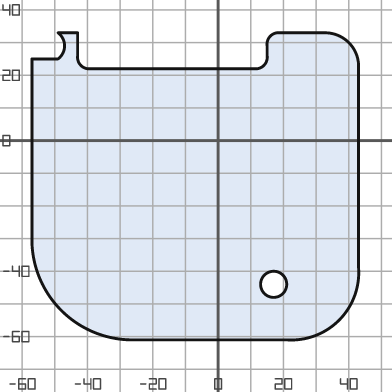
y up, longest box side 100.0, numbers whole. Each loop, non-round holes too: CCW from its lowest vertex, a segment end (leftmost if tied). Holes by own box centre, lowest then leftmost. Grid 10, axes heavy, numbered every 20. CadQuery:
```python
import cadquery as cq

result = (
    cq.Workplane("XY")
    .moveTo(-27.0, -61.0)
    .lineTo(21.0, -61.0)
    .threePointArc((37.0, -55.0), (43.0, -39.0))
    .lineTo(43.0, 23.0)
    .threePointArc((40.0, 30.0), (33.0, 33.0))
    .lineTo(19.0, 33.0)
    .threePointArc((16.0, 32.0), (15.0, 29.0))
    .lineTo(15.0, 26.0)
    .threePointArc((14.0, 23.0), (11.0, 22.0))
    .lineTo(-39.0, 22.0)
    .threePointArc((-42.0, 23.0), (-43.0, 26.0))
    .lineTo(-43.0, 33.0)
    .lineTo(-49.0, 33.0)
    .threePointArc((-47.0, 29.0), (-49.0, 25.0))
    .lineTo(-57.0, 25.0)
    .lineTo(-57.0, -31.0)
    .threePointArc((-48.0, -52.0), (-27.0, -61.0))
    .close()
    .moveTo(17.0, -44.0)
    .circle(4.0)
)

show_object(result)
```